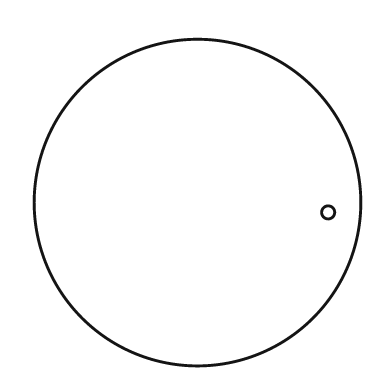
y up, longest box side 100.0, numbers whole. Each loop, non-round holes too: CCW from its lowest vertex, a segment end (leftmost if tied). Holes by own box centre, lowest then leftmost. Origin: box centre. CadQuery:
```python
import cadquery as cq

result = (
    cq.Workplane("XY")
    .moveTo(0.0, 0.0)
    .circle(50.0)
    .moveTo(40.0, -3.0)
    .circle(2.0)
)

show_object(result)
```